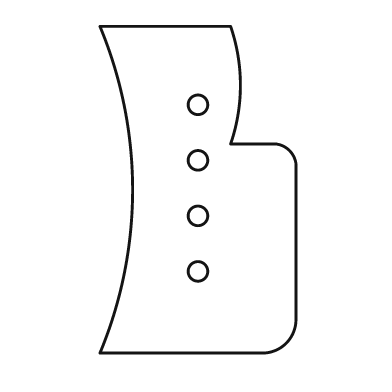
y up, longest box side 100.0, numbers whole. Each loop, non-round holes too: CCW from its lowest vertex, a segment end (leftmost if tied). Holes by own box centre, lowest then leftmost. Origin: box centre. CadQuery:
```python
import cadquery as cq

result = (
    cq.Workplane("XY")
    .moveTo(-30.0, -50.0)
    .lineTo(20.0, -50.0)
    .threePointArc((27.0, -47.0), (30.0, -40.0))
    .lineTo(30.0, 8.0)
    .threePointArc((28.0, 12.0), (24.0, 14.0))
    .lineTo(10.0, 14.0)
    .threePointArc((13.0, 32.0), (10.0, 50.0))
    .lineTo(-30.0, 50.0)
    .threePointArc((-20.0, 0.0), (-30.0, -50.0))
    .close()
    .moveTo(0.0, -25.0)
    .circle(3.0)
    .moveTo(0.0, -8.0)
    .circle(3.0)
    .moveTo(0.0, 9.0)
    .circle(3.0)
    .moveTo(0.0, 26.0)
    .circle(3.0)
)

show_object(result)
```